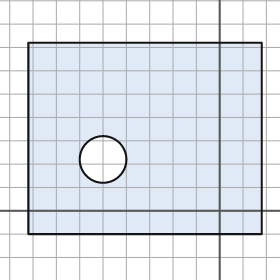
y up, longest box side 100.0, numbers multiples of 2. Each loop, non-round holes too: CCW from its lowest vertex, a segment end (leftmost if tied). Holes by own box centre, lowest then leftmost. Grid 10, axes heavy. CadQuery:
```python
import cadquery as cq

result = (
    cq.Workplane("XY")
    .moveTo(-82.0, -10.0)
    .lineTo(18.0, -10.0)
    .lineTo(18.0, 72.0)
    .lineTo(-82.0, 72.0)
    .close()
    .moveTo(-50.0, 22.0)
    .circle(10.0)
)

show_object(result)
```